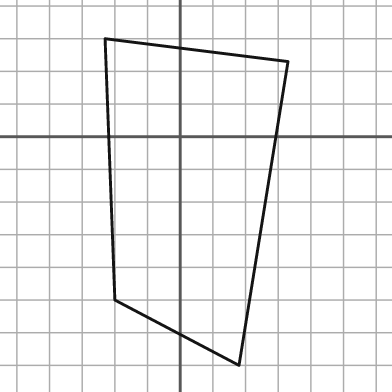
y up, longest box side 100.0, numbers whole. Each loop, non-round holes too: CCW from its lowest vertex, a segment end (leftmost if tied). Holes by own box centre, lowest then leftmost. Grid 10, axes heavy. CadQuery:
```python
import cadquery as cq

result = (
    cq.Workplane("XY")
    .moveTo(18.0, -70.0)
    .lineTo(33.0, 23.0)
    .lineTo(-23.0, 30.0)
    .lineTo(-20.0, -50.0)
    .close()
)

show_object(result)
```